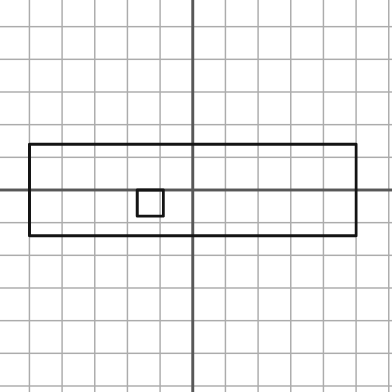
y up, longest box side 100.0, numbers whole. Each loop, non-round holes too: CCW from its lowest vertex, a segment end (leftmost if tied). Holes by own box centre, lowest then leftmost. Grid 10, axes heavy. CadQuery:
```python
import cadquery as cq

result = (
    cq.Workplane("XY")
    .moveTo(-50.0, -14.0)
    .lineTo(50.0, -14.0)
    .lineTo(50.0, 14.0)
    .lineTo(-50.0, 14.0)
    .close()
    .moveTo(-17.0, -8.0)
    .lineTo(-9.0, -8.0)
    .lineTo(-9.0, 0.0)
    .lineTo(-17.0, 0.0)
    .close()
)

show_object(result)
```